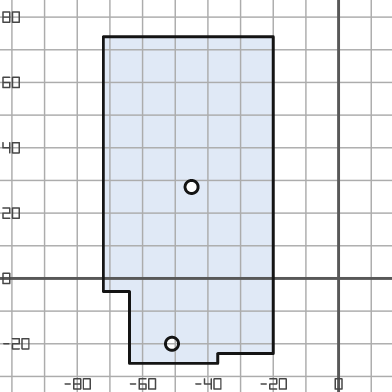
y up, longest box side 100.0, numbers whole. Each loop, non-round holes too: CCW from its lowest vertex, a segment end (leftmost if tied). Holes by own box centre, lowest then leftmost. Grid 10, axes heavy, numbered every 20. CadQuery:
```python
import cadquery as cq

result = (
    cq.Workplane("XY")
    .moveTo(-64.0, -26.0)
    .lineTo(-37.0, -26.0)
    .lineTo(-37.0, -23.0)
    .lineTo(-20.0, -23.0)
    .lineTo(-20.0, 74.0)
    .lineTo(-72.0, 74.0)
    .lineTo(-72.0, -4.0)
    .lineTo(-64.0, -4.0)
    .close()
    .moveTo(-51.0, -20.0)
    .circle(2.0)
    .moveTo(-45.0, 28.0)
    .circle(2.0)
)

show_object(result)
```